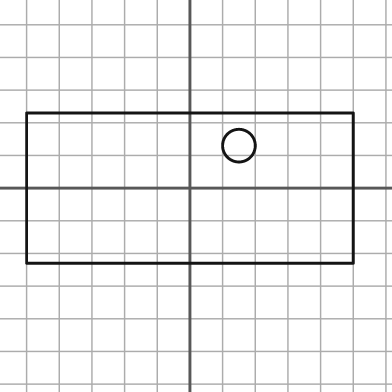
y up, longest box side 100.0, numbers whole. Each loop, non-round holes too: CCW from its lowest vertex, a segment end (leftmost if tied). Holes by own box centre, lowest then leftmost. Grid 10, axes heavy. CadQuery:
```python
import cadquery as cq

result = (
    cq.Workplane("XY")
    .moveTo(-50.0, -23.0)
    .lineTo(50.0, -23.0)
    .lineTo(50.0, 23.0)
    .lineTo(-50.0, 23.0)
    .close()
    .moveTo(15.0, 13.0)
    .circle(5.0)
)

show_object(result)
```